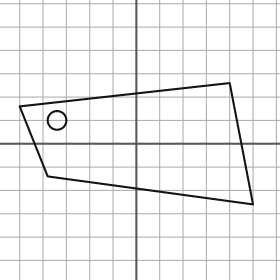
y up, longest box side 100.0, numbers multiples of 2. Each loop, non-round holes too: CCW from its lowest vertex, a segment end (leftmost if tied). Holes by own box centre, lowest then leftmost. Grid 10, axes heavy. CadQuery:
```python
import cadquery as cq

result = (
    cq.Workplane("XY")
    .moveTo(50.0, -26.0)
    .lineTo(40.0, 26.0)
    .lineTo(-50.0, 16.0)
    .lineTo(-38.0, -14.0)
    .close()
    .moveTo(-34.0, 10.0)
    .circle(4.0)
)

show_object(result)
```